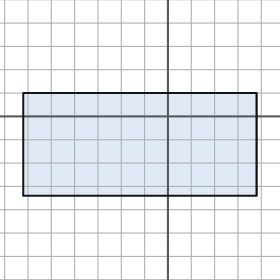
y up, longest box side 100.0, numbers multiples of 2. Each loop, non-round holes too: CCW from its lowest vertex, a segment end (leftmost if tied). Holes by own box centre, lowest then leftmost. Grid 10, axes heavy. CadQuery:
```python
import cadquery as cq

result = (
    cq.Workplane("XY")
    .moveTo(-62.0, -34.0)
    .lineTo(38.0, -34.0)
    .lineTo(38.0, 10.0)
    .lineTo(-62.0, 10.0)
    .close()
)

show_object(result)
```